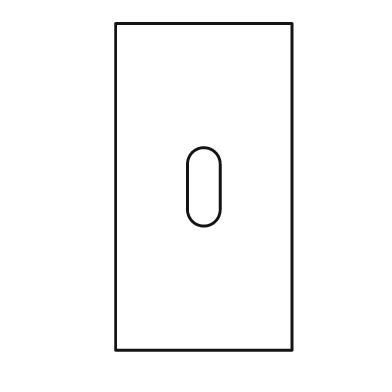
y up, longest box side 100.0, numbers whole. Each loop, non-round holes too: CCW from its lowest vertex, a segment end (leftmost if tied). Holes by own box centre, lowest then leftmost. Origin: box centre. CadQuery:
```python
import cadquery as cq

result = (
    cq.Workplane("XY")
    .moveTo(-27.0, -50.0)
    .lineTo(27.0, -50.0)
    .lineTo(27.0, 50.0)
    .lineTo(-27.0, 50.0)
    .close()
    .moveTo(-5.0, -7.0)
    .threePointArc((0.0, -12.0), (5.0, -7.0))
    .lineTo(5.0, 7.0)
    .threePointArc((0.0, 12.0), (-5.0, 7.0))
    .close()
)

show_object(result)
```